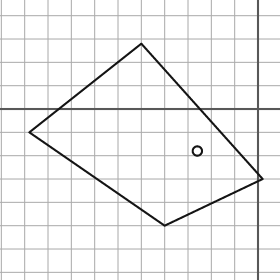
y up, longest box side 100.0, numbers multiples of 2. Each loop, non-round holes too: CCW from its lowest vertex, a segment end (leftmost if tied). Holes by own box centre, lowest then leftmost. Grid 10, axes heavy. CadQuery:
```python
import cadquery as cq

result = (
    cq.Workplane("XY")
    .moveTo(-40.0, -50.0)
    .lineTo(2.0, -30.0)
    .lineTo(-50.0, 28.0)
    .lineTo(-98.0, -10.0)
    .close()
    .moveTo(-26.0, -18.0)
    .circle(2.0)
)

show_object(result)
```